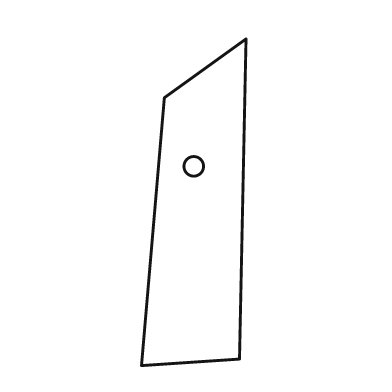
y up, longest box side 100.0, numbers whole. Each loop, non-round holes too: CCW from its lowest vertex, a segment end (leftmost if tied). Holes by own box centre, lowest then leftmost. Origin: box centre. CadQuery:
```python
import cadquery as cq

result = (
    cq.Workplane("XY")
    .moveTo(-16.0, -50.0)
    .lineTo(14.0, -48.0)
    .lineTo(16.0, 50.0)
    .lineTo(-9.0, 32.0)
    .close()
    .moveTo(0.0, 11.0)
    .circle(3.0)
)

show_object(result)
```